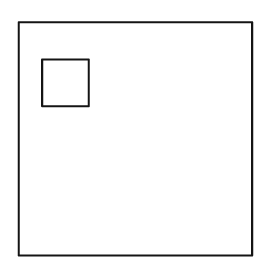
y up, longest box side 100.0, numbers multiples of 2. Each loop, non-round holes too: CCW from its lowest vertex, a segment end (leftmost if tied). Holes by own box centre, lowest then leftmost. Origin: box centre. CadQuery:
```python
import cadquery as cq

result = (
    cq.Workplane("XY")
    .moveTo(-50.0, -50.0)
    .lineTo(50.0, -50.0)
    .lineTo(50.0, 50.0)
    .lineTo(-50.0, 50.0)
    .close()
    .moveTo(-40.0, 14.0)
    .lineTo(-20.0, 14.0)
    .lineTo(-20.0, 34.0)
    .lineTo(-40.0, 34.0)
    .close()
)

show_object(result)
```